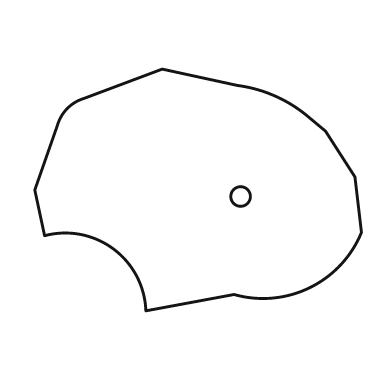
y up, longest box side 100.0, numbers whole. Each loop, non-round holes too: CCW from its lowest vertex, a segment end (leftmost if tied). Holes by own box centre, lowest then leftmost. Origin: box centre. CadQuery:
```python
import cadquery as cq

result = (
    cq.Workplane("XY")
    .moveTo(-16.0, -37.0)
    .lineTo(11.0, -32.0)
    .threePointArc((34.0, -30.0), (50.0, -13.0))
    .lineTo(48.0, 4.0)
    .lineTo(39.0, 18.0)
    .lineTo(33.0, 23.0)
    .threePointArc((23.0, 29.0), (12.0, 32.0))
    .lineTo(-11.0, 37.0)
    .lineTo(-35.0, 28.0)
    .threePointArc((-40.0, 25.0), (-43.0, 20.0))
    .lineTo(-50.0, 0.0)
    .lineTo(-47.0, -14.0)
    .threePointArc((-26.0, -18.0), (-16.0, -37.0))
    .close()
    .moveTo(13.0, -2.0)
    .circle(3.0)
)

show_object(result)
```